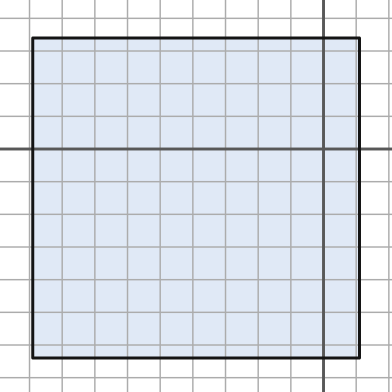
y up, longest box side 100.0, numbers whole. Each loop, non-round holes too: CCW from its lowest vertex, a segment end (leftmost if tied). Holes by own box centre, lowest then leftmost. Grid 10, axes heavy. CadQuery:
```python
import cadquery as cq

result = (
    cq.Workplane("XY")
    .moveTo(-89.0, -64.0)
    .lineTo(11.0, -64.0)
    .lineTo(11.0, 34.0)
    .lineTo(-89.0, 34.0)
    .close()
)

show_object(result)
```